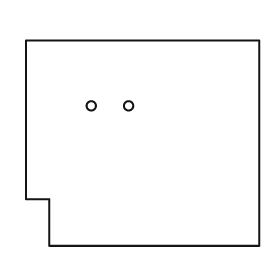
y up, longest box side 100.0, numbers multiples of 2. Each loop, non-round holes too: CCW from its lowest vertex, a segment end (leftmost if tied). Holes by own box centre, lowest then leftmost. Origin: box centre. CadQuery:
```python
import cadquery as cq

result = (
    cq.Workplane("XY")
    .moveTo(-40.0, -44.0)
    .lineTo(50.0, -44.0)
    .lineTo(50.0, 44.0)
    .lineTo(-50.0, 44.0)
    .lineTo(-50.0, -24.0)
    .lineTo(-40.0, -24.0)
    .close()
    .moveTo(-22.0, 16.0)
    .circle(2.0)
    .moveTo(-6.0, 16.0)
    .circle(2.0)
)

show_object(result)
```